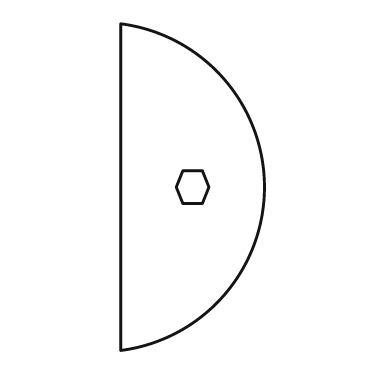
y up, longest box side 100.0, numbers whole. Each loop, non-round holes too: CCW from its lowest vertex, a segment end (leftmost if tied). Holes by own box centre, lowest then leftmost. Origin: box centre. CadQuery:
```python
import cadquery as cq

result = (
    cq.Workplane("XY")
    .moveTo(-22.0, -50.0)
    .threePointArc((22.0, 0.0), (-22.0, 50.0))
    .close()
    .moveTo(-3.0, -5.0)
    .lineTo(3.0, -5.0)
    .lineTo(5.0, 0.0)
    .lineTo(3.0, 5.0)
    .lineTo(-3.0, 5.0)
    .lineTo(-5.0, 0.0)
    .close()
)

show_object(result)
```